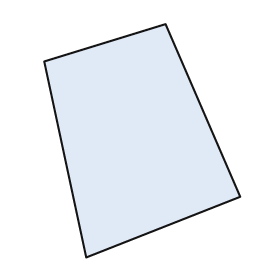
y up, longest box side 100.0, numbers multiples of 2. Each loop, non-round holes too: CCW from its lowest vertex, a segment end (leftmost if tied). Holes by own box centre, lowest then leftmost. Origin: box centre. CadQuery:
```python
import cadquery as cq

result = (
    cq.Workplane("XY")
    .moveTo(-24.0, -50.0)
    .lineTo(42.0, -24.0)
    .lineTo(10.0, 50.0)
    .lineTo(-42.0, 34.0)
    .close()
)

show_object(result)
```